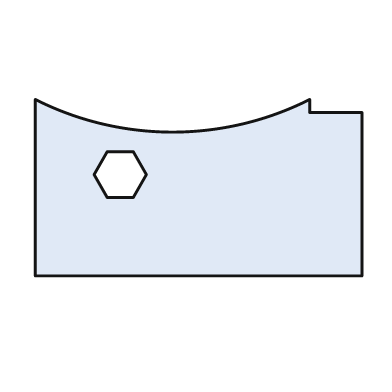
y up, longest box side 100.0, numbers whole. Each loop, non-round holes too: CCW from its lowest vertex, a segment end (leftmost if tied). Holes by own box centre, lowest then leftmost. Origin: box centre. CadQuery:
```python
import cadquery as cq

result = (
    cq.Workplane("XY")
    .moveTo(-50.0, -27.0)
    .lineTo(50.0, -27.0)
    .lineTo(50.0, 23.0)
    .lineTo(34.0, 23.0)
    .lineTo(34.0, 27.0)
    .threePointArc((-8.0, 17.0), (-50.0, 27.0))
    .close()
    .moveTo(-28.0, -3.0)
    .lineTo(-20.0, -3.0)
    .lineTo(-16.0, 4.0)
    .lineTo(-20.0, 11.0)
    .lineTo(-28.0, 11.0)
    .lineTo(-32.0, 4.0)
    .close()
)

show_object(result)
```